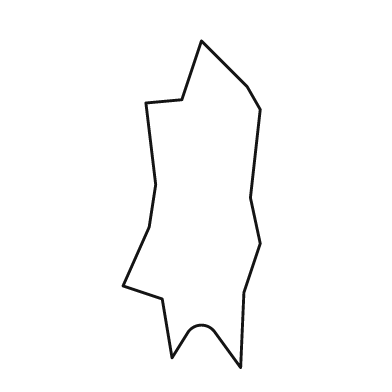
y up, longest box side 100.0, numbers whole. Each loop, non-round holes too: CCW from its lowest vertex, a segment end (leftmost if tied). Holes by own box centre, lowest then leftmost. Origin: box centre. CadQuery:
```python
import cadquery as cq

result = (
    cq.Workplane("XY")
    .moveTo(15.0, -50.0)
    .lineTo(16.0, -27.0)
    .lineTo(21.0, -12.0)
    .lineTo(18.0, 2.0)
    .lineTo(21.0, 29.0)
    .lineTo(17.0, 36.0)
    .lineTo(3.0, 50.0)
    .lineTo(-3.0, 32.0)
    .lineTo(-14.0, 31.0)
    .lineTo(-11.0, 6.0)
    .lineTo(-13.0, -7.0)
    .lineTo(-21.0, -25.0)
    .lineTo(-9.0, -29.0)
    .lineTo(-6.0, -47.0)
    .lineTo(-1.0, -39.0)
    .threePointArc((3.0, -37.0), (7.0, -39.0))
    .close()
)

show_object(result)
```